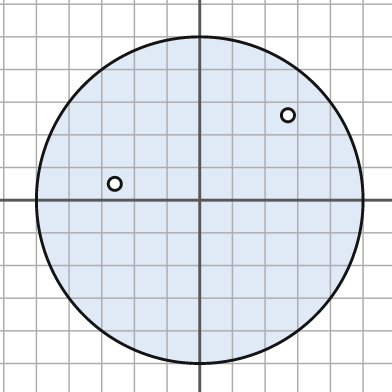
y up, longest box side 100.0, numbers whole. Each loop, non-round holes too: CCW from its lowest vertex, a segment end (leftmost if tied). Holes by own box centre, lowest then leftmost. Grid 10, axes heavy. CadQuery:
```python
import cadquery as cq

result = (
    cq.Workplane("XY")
    .moveTo(0.0, 0.0)
    .circle(50.0)
    .moveTo(-26.0, 5.0)
    .circle(2.0)
    .moveTo(27.0, 26.0)
    .circle(2.0)
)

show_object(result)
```